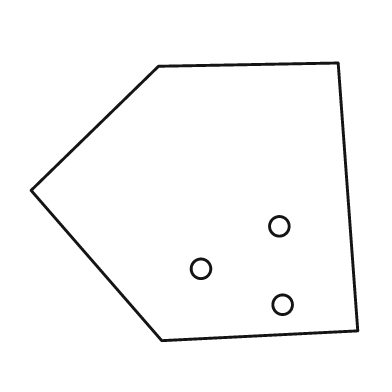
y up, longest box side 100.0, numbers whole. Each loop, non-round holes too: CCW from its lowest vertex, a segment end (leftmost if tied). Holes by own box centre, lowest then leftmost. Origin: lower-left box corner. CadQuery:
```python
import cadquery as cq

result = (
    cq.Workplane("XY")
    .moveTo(40.0, 0.0)
    .lineTo(100.0, 3.0)
    .lineTo(94.0, 85.0)
    .lineTo(39.0, 84.0)
    .lineTo(0.0, 46.0)
    .close()
    .moveTo(77.0, 11.0)
    .circle(3.0)
    .moveTo(52.0, 22.0)
    .circle(3.0)
    .moveTo(76.0, 35.0)
    .circle(3.0)
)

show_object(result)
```